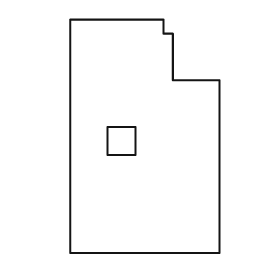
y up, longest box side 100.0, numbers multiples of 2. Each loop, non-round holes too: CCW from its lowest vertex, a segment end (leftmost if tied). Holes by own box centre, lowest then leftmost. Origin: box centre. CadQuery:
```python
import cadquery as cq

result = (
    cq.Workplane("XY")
    .moveTo(-32.0, -50.0)
    .lineTo(32.0, -50.0)
    .lineTo(32.0, 24.0)
    .lineTo(12.0, 24.0)
    .lineTo(12.0, 44.0)
    .lineTo(8.0, 44.0)
    .lineTo(8.0, 50.0)
    .lineTo(-32.0, 50.0)
    .close()
    .moveTo(-16.0, -8.0)
    .lineTo(-4.0, -8.0)
    .lineTo(-4.0, 4.0)
    .lineTo(-16.0, 4.0)
    .close()
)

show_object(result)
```